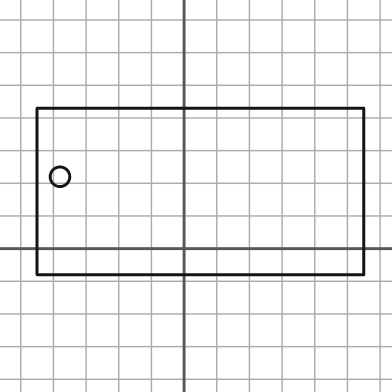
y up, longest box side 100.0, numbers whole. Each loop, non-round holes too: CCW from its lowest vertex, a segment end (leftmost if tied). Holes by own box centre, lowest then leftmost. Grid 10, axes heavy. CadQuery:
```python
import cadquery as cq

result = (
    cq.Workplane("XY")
    .moveTo(-45.0, -8.0)
    .lineTo(55.0, -8.0)
    .lineTo(55.0, 43.0)
    .lineTo(-45.0, 43.0)
    .close()
    .moveTo(-38.0, 22.0)
    .circle(3.0)
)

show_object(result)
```